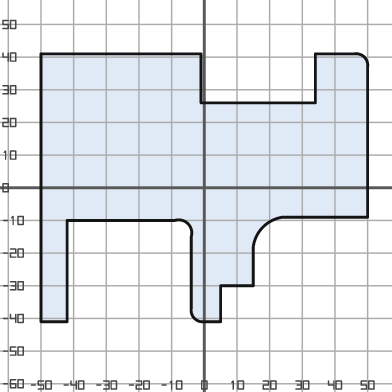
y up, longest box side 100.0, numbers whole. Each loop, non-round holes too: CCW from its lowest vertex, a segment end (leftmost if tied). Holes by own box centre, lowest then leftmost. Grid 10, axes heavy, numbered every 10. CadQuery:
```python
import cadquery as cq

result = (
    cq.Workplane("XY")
    .moveTo(-50.0, -41.0)
    .lineTo(-42.0, -41.0)
    .lineTo(-42.0, -10.0)
    .lineTo(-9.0, -10.0)
    .threePointArc((-5.0, -11.0), (-4.0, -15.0))
    .lineTo(-4.0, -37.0)
    .threePointArc((-3.0, -40.0), (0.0, -41.0))
    .lineTo(5.0, -41.0)
    .lineTo(5.0, -30.0)
    .lineTo(15.0, -30.0)
    .lineTo(15.0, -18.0)
    .threePointArc((18.0, -12.0), (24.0, -9.0))
    .lineTo(50.0, -9.0)
    .lineTo(50.0, 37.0)
    .threePointArc((49.0, 40.0), (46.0, 41.0))
    .lineTo(34.0, 41.0)
    .lineTo(34.0, 26.0)
    .lineTo(-1.0, 26.0)
    .lineTo(-1.0, 41.0)
    .lineTo(-50.0, 41.0)
    .close()
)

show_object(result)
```